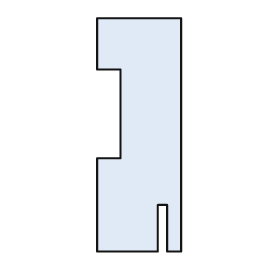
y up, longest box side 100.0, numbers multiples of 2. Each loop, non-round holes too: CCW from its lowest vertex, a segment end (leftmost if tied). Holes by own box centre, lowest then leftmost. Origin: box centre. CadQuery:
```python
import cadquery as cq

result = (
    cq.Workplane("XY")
    .moveTo(-18.0, -50.0)
    .lineTo(8.0, -50.0)
    .lineTo(8.0, -30.0)
    .lineTo(12.0, -30.0)
    .lineTo(12.0, -50.0)
    .lineTo(18.0, -50.0)
    .lineTo(18.0, 50.0)
    .lineTo(-18.0, 50.0)
    .lineTo(-18.0, 28.0)
    .lineTo(-8.0, 28.0)
    .lineTo(-8.0, -10.0)
    .lineTo(-18.0, -10.0)
    .close()
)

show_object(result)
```